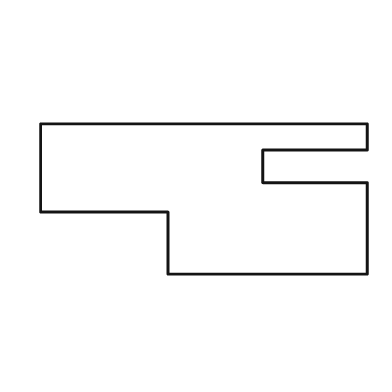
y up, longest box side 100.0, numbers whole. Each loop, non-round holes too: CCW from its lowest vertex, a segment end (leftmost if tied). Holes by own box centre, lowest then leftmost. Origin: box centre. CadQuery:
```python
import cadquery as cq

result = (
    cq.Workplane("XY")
    .moveTo(-11.0, -23.0)
    .lineTo(50.0, -23.0)
    .lineTo(50.0, 5.0)
    .lineTo(18.0, 5.0)
    .lineTo(18.0, 15.0)
    .lineTo(50.0, 15.0)
    .lineTo(50.0, 23.0)
    .lineTo(-50.0, 23.0)
    .lineTo(-50.0, -4.0)
    .lineTo(-11.0, -4.0)
    .close()
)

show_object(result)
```